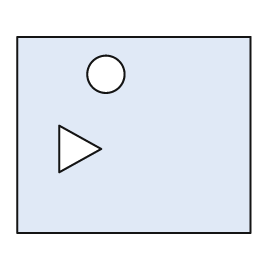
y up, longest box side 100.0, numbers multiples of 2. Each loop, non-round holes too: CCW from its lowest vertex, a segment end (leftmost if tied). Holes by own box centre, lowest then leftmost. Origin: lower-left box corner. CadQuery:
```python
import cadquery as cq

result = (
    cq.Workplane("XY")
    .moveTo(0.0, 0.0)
    .lineTo(100.0, 0.0)
    .lineTo(100.0, 84.0)
    .lineTo(0.0, 84.0)
    .close()
    .moveTo(18.0, 26.0)
    .lineTo(36.0, 36.0)
    .lineTo(18.0, 46.0)
    .close()
    .moveTo(38.0, 68.0)
    .circle(8.0)
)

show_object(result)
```